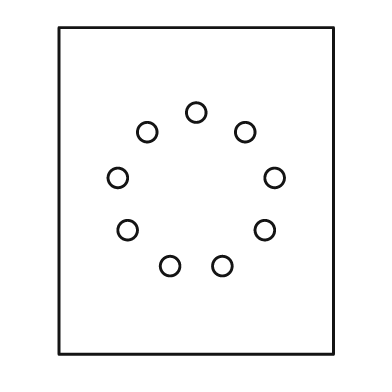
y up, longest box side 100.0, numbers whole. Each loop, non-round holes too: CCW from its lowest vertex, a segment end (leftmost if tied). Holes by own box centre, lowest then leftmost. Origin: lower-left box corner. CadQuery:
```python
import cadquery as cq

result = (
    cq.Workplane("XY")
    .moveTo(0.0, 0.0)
    .lineTo(84.0, 0.0)
    .lineTo(84.0, 100.0)
    .lineTo(0.0, 100.0)
    .close()
    .moveTo(34.0, 27.0)
    .circle(3.0)
    .moveTo(50.0, 27.0)
    .circle(3.0)
    .moveTo(21.0, 38.0)
    .circle(3.0)
    .moveTo(63.0, 38.0)
    .circle(3.0)
    .moveTo(18.0, 54.0)
    .circle(3.0)
    .moveTo(66.0, 54.0)
    .circle(3.0)
    .moveTo(27.0, 68.0)
    .circle(3.0)
    .moveTo(57.0, 68.0)
    .circle(3.0)
    .moveTo(42.0, 74.0)
    .circle(3.0)
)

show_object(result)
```